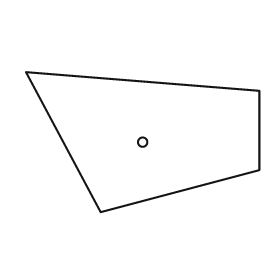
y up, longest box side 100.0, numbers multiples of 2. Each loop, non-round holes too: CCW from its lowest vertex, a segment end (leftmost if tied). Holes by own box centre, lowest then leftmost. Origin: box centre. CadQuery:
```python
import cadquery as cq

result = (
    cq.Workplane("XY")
    .moveTo(-18.0, -30.0)
    .lineTo(50.0, -12.0)
    .lineTo(50.0, 22.0)
    .lineTo(-50.0, 30.0)
    .close()
    .moveTo(0.0, 0.0)
    .circle(2.0)
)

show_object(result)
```